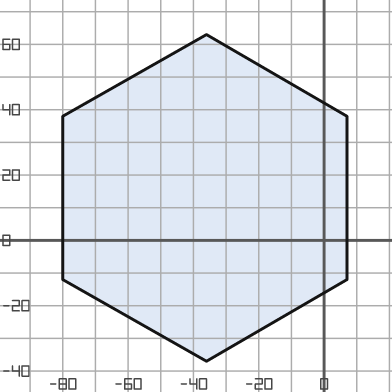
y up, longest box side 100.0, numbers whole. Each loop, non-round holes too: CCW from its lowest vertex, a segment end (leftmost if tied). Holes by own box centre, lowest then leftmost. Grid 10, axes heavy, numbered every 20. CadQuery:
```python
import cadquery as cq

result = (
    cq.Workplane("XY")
    .moveTo(-36.0, -37.0)
    .lineTo(7.0, -12.0)
    .lineTo(7.0, 38.0)
    .lineTo(-36.0, 63.0)
    .lineTo(-80.0, 38.0)
    .lineTo(-80.0, -12.0)
    .close()
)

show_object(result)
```